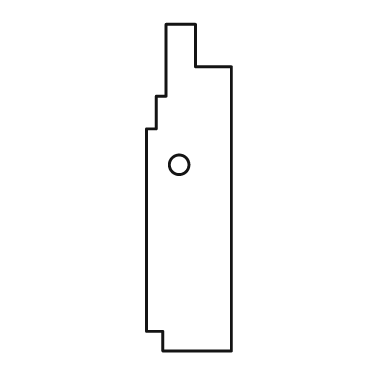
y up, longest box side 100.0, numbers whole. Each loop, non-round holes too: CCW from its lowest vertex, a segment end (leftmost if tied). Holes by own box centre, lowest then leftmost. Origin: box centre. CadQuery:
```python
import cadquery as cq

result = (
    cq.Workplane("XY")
    .moveTo(-8.0, -50.0)
    .lineTo(13.0, -50.0)
    .lineTo(13.0, 37.0)
    .lineTo(2.0, 37.0)
    .lineTo(2.0, 50.0)
    .lineTo(-7.0, 50.0)
    .lineTo(-7.0, 28.0)
    .lineTo(-10.0, 28.0)
    .lineTo(-10.0, 18.0)
    .lineTo(-13.0, 18.0)
    .lineTo(-13.0, -44.0)
    .lineTo(-8.0, -44.0)
    .close()
    .moveTo(-3.0, 7.0)
    .circle(3.0)
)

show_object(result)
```